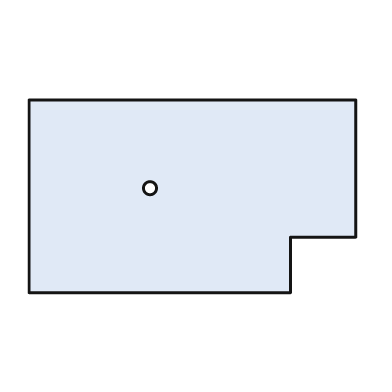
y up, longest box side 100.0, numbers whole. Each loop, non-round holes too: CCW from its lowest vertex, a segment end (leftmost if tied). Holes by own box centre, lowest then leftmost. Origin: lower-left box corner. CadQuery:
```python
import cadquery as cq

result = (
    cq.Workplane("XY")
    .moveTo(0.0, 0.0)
    .lineTo(80.0, 0.0)
    .lineTo(80.0, 17.0)
    .lineTo(100.0, 17.0)
    .lineTo(100.0, 59.0)
    .lineTo(0.0, 59.0)
    .close()
    .moveTo(37.0, 32.0)
    .circle(2.0)
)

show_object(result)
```